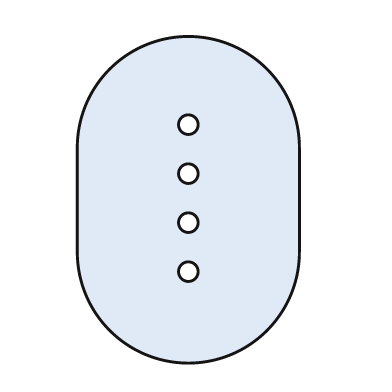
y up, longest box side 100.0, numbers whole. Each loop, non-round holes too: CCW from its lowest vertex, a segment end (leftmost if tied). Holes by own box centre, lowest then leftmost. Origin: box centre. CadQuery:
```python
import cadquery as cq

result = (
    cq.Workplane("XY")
    .moveTo(-34.0, -16.0)
    .threePointArc((0.0, -50.0), (34.0, -16.0))
    .lineTo(34.0, 16.0)
    .threePointArc((0.0, 50.0), (-34.0, 16.0))
    .close()
    .moveTo(0.0, -22.0)
    .circle(3.0)
    .moveTo(0.0, -7.0)
    .circle(3.0)
    .moveTo(0.0, 8.0)
    .circle(3.0)
    .moveTo(0.0, 23.0)
    .circle(3.0)
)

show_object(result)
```